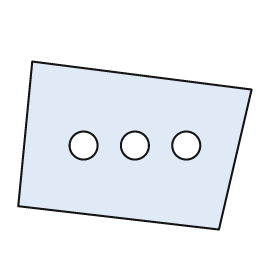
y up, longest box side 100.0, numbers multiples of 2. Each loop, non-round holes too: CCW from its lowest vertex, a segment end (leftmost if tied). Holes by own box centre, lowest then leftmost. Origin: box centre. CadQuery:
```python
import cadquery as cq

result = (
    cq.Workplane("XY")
    .moveTo(36.0, -36.0)
    .lineTo(50.0, 24.0)
    .lineTo(-44.0, 36.0)
    .lineTo(-50.0, -26.0)
    .close()
    .moveTo(-22.0, 0.0)
    .circle(6.0)
    .moveTo(0.0, 0.0)
    .circle(6.0)
    .moveTo(22.0, 0.0)
    .circle(6.0)
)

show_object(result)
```